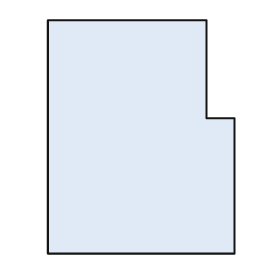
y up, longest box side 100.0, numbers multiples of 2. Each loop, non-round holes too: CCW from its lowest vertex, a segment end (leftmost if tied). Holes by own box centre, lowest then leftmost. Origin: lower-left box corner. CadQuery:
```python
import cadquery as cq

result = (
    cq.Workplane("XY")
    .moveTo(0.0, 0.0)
    .lineTo(80.0, 0.0)
    .lineTo(80.0, 58.0)
    .lineTo(68.0, 58.0)
    .lineTo(68.0, 100.0)
    .lineTo(0.0, 100.0)
    .close()
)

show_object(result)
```